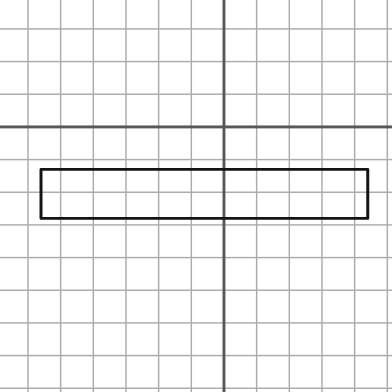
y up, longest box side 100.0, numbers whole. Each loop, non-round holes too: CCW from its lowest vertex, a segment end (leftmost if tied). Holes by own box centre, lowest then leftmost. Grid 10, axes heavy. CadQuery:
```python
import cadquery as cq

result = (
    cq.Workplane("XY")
    .moveTo(-56.0, -28.0)
    .lineTo(44.0, -28.0)
    .lineTo(44.0, -13.0)
    .lineTo(-56.0, -13.0)
    .close()
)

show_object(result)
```